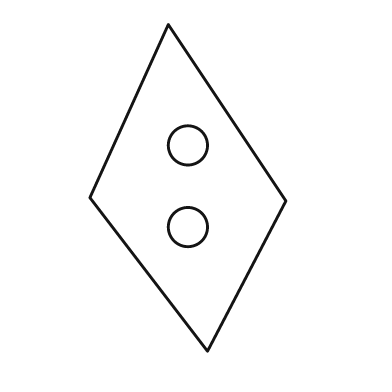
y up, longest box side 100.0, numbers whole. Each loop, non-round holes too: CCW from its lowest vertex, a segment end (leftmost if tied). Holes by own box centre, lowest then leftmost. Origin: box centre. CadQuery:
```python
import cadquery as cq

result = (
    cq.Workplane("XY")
    .moveTo(6.0, -50.0)
    .lineTo(30.0, -4.0)
    .lineTo(-6.0, 50.0)
    .lineTo(-30.0, -3.0)
    .close()
    .moveTo(0.0, -12.0)
    .circle(6.0)
    .moveTo(0.0, 13.0)
    .circle(6.0)
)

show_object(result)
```